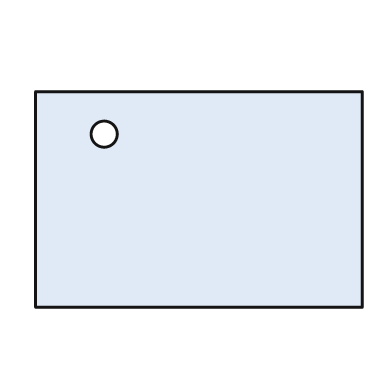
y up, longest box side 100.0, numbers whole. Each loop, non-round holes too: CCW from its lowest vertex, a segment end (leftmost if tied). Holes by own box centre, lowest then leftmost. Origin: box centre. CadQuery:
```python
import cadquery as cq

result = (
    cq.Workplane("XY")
    .moveTo(-50.0, -33.0)
    .lineTo(50.0, -33.0)
    .lineTo(50.0, 33.0)
    .lineTo(-50.0, 33.0)
    .close()
    .moveTo(-29.0, 20.0)
    .circle(4.0)
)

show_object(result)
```